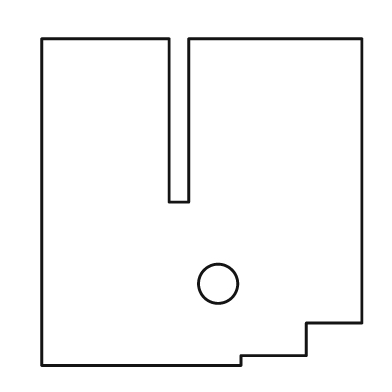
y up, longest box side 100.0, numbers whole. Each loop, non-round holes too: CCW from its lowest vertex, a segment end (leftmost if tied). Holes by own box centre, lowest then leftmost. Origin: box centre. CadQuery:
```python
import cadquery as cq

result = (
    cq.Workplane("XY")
    .moveTo(-49.0, -50.0)
    .lineTo(12.0, -50.0)
    .lineTo(12.0, -47.0)
    .lineTo(32.0, -47.0)
    .lineTo(32.0, -37.0)
    .lineTo(49.0, -37.0)
    .lineTo(49.0, 50.0)
    .lineTo(-4.0, 50.0)
    .lineTo(-4.0, 0.0)
    .lineTo(-10.0, 0.0)
    .lineTo(-10.0, 50.0)
    .lineTo(-49.0, 50.0)
    .close()
    .moveTo(5.0, -25.0)
    .circle(6.0)
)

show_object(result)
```